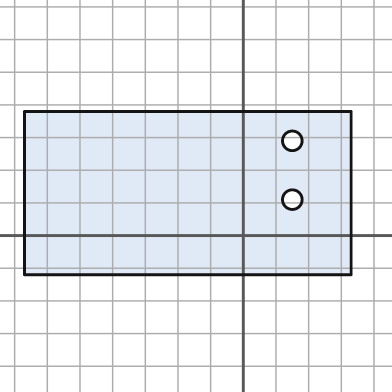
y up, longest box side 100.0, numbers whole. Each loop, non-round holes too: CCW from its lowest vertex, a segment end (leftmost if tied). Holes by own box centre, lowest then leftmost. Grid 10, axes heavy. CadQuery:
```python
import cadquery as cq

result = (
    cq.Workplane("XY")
    .moveTo(-67.0, -12.0)
    .lineTo(33.0, -12.0)
    .lineTo(33.0, 38.0)
    .lineTo(-67.0, 38.0)
    .close()
    .moveTo(15.0, 11.0)
    .circle(3.0)
    .moveTo(15.0, 29.0)
    .circle(3.0)
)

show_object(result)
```